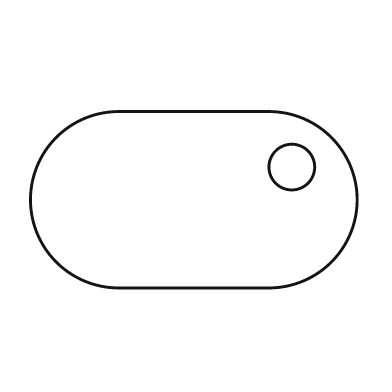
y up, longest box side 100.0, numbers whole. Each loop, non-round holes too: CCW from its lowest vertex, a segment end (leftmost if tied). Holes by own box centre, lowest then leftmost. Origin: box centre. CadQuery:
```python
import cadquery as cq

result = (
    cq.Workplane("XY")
    .moveTo(-23.0, -27.0)
    .lineTo(23.0, -27.0)
    .threePointArc((50.0, 0.0), (23.0, 27.0))
    .lineTo(-23.0, 27.0)
    .threePointArc((-50.0, 0.0), (-23.0, -27.0))
    .close()
    .moveTo(30.0, 10.0)
    .circle(7.0)
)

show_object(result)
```